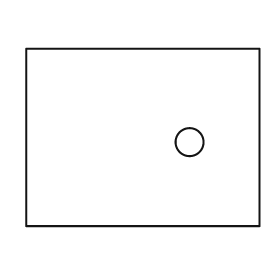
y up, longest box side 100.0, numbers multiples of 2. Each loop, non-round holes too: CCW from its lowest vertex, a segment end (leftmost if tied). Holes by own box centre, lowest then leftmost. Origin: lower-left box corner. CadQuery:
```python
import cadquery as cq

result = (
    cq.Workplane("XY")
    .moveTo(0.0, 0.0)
    .lineTo(100.0, 0.0)
    .lineTo(100.0, 76.0)
    .lineTo(0.0, 76.0)
    .close()
    .moveTo(70.0, 36.0)
    .circle(6.0)
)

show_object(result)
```